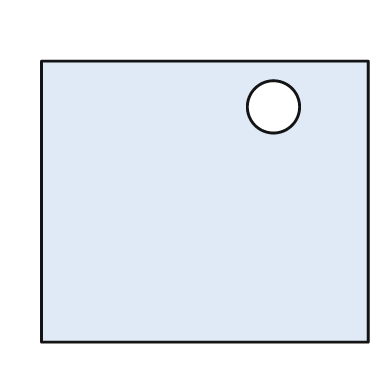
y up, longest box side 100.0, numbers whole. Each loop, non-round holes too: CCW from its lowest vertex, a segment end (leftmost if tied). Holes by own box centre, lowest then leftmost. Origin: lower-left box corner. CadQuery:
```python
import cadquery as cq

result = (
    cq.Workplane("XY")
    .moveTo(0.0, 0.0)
    .lineTo(100.0, 0.0)
    .lineTo(100.0, 86.0)
    .lineTo(0.0, 86.0)
    .close()
    .moveTo(71.0, 72.0)
    .circle(8.0)
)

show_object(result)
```